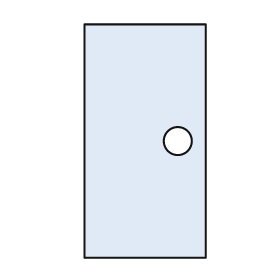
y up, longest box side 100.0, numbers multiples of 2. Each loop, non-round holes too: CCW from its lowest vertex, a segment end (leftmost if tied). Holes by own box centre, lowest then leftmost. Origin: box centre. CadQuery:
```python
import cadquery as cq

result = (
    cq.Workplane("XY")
    .moveTo(-26.0, -50.0)
    .lineTo(26.0, -50.0)
    .lineTo(26.0, 50.0)
    .lineTo(-26.0, 50.0)
    .close()
    .moveTo(14.0, 0.0)
    .circle(6.0)
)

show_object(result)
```